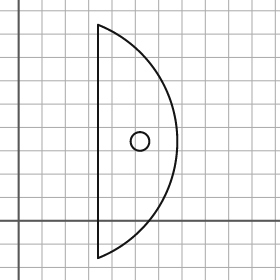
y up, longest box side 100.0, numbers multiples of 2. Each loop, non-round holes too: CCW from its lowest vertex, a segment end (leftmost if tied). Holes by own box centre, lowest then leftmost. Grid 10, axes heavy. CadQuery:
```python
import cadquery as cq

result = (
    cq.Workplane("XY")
    .moveTo(34.0, -16.0)
    .threePointArc((68.0, 34.0), (34.0, 84.0))
    .close()
    .moveTo(52.0, 34.0)
    .circle(4.0)
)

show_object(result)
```